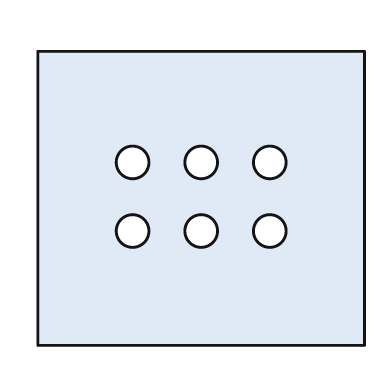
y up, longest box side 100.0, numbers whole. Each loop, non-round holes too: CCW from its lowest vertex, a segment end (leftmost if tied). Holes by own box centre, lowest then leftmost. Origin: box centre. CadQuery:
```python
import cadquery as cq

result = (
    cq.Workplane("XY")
    .moveTo(-50.0, -45.0)
    .lineTo(50.0, -45.0)
    .lineTo(50.0, 45.0)
    .lineTo(-50.0, 45.0)
    .close()
    .moveTo(-21.0, -10.0)
    .circle(5.0)
    .moveTo(0.0, -10.0)
    .circle(5.0)
    .moveTo(21.0, -10.0)
    .circle(5.0)
    .moveTo(-21.0, 11.0)
    .circle(5.0)
    .moveTo(0.0, 11.0)
    .circle(5.0)
    .moveTo(21.0, 11.0)
    .circle(5.0)
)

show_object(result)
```